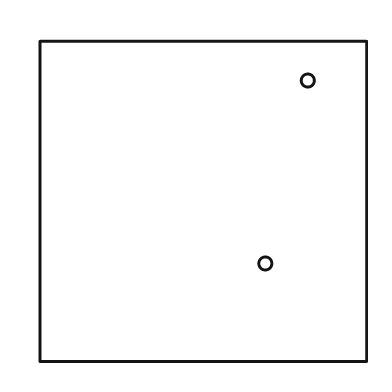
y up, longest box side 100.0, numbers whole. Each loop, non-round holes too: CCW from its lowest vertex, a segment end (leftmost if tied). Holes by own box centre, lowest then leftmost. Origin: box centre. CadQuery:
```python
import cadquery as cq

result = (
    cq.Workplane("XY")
    .moveTo(-50.0, -49.0)
    .lineTo(50.0, -49.0)
    .lineTo(50.0, 49.0)
    .lineTo(-50.0, 49.0)
    .close()
    .moveTo(19.0, -19.0)
    .circle(2.0)
    .moveTo(32.0, 37.0)
    .circle(2.0)
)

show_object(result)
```